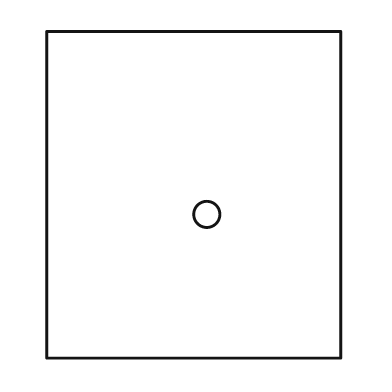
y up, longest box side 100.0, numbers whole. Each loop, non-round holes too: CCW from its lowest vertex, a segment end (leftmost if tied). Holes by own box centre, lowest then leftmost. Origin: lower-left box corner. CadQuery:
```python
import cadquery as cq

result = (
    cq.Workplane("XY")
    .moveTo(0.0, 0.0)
    .lineTo(90.0, 0.0)
    .lineTo(90.0, 100.0)
    .lineTo(0.0, 100.0)
    .close()
    .moveTo(49.0, 44.0)
    .circle(4.0)
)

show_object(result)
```